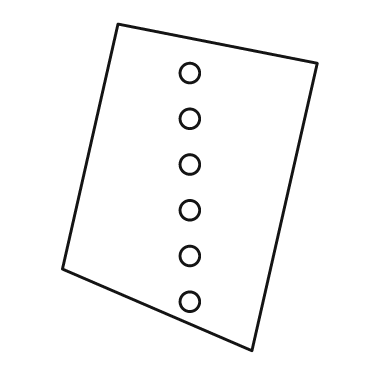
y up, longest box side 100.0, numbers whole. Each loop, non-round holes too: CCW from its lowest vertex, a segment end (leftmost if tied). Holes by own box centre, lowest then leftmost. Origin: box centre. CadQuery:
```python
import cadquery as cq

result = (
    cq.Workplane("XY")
    .moveTo(19.0, -50.0)
    .lineTo(39.0, 38.0)
    .lineTo(-22.0, 50.0)
    .lineTo(-39.0, -25.0)
    .close()
    .moveTo(0.0, -35.0)
    .circle(3.0)
    .moveTo(0.0, -21.0)
    .circle(3.0)
    .moveTo(0.0, -7.0)
    .circle(3.0)
    .moveTo(0.0, 7.0)
    .circle(3.0)
    .moveTo(0.0, 21.0)
    .circle(3.0)
    .moveTo(0.0, 35.0)
    .circle(3.0)
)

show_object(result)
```